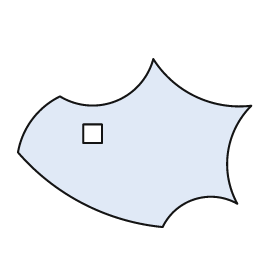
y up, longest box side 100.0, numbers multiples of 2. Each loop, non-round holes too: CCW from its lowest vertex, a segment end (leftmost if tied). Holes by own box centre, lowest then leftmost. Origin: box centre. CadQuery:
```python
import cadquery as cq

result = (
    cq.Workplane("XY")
    .moveTo(12.0, -36.0)
    .threePointArc((26.0, -24.0), (44.0, -26.0))
    .threePointArc((40.0, -4.0), (50.0, 16.0))
    .threePointArc((26.0, 20.0), (8.0, 36.0))
    .threePointArc((-8.0, 18.0), (-32.0, 20.0))
    .threePointArc((-44.0, 10.0), (-50.0, -4.0))
    .threePointArc((-22.0, -26.0), (12.0, -36.0))
    .close()
    .moveTo(-22.0, 0.0)
    .lineTo(-14.0, 0.0)
    .lineTo(-14.0, 8.0)
    .lineTo(-22.0, 8.0)
    .close()
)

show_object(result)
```